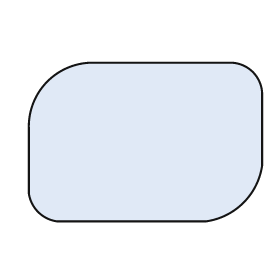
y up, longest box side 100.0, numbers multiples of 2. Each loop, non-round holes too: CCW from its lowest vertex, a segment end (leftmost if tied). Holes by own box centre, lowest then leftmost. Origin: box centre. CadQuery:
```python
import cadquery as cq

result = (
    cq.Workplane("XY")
    .moveTo(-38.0, -34.0)
    .lineTo(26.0, -34.0)
    .threePointArc((42.0, -26.0), (50.0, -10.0))
    .lineTo(50.0, 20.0)
    .threePointArc((46.0, 30.0), (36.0, 34.0))
    .lineTo(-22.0, 34.0)
    .threePointArc((-42.0, 26.0), (-50.0, 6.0))
    .lineTo(-50.0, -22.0)
    .threePointArc((-46.0, -30.0), (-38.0, -34.0))
    .close()
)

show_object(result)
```